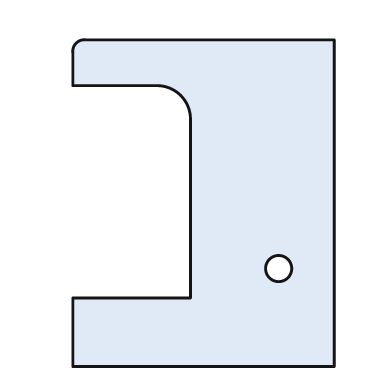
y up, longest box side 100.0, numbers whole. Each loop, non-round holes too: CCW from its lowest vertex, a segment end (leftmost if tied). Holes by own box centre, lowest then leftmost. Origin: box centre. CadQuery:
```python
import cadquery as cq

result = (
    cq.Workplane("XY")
    .moveTo(-40.0, -50.0)
    .lineTo(40.0, -50.0)
    .lineTo(40.0, 50.0)
    .lineTo(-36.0, 50.0)
    .threePointArc((-39.0, 49.0), (-40.0, 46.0))
    .lineTo(-40.0, 36.0)
    .lineTo(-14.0, 36.0)
    .threePointArc((-7.0, 33.0), (-4.0, 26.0))
    .lineTo(-4.0, -29.0)
    .lineTo(-40.0, -29.0)
    .close()
    .moveTo(23.0, -20.0)
    .circle(4.0)
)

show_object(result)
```